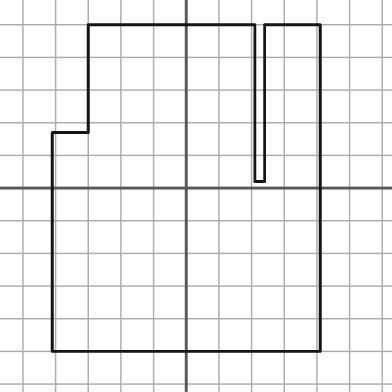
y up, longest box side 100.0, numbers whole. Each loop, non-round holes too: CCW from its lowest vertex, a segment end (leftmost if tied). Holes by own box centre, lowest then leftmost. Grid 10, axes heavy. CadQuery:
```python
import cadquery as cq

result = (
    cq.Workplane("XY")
    .moveTo(-41.0, -50.0)
    .lineTo(41.0, -50.0)
    .lineTo(41.0, 50.0)
    .lineTo(24.0, 50.0)
    .lineTo(24.0, 2.0)
    .lineTo(21.0, 2.0)
    .lineTo(21.0, 50.0)
    .lineTo(-30.0, 50.0)
    .lineTo(-30.0, 17.0)
    .lineTo(-41.0, 17.0)
    .close()
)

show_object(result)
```